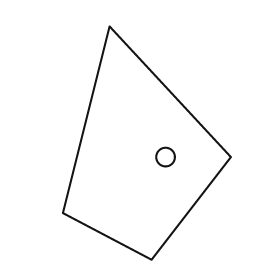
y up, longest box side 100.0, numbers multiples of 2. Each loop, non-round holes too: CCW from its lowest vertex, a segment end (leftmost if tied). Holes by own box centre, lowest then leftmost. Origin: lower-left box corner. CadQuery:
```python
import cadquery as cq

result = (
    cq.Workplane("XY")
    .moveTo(38.0, 0.0)
    .lineTo(72.0, 44.0)
    .lineTo(20.0, 100.0)
    .lineTo(0.0, 20.0)
    .close()
    .moveTo(44.0, 44.0)
    .circle(4.0)
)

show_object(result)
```